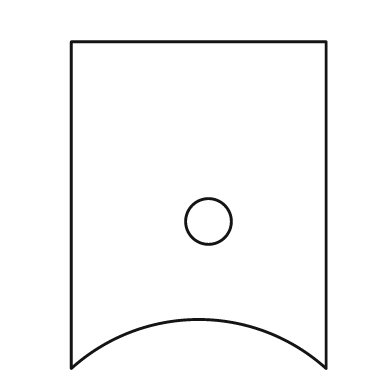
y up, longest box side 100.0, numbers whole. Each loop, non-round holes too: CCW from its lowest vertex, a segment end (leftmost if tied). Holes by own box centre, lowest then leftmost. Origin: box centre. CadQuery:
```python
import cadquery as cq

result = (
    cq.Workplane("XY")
    .moveTo(-39.0, -50.0)
    .threePointArc((0.0, -35.0), (39.0, -50.0))
    .lineTo(39.0, 50.0)
    .lineTo(-39.0, 50.0)
    .close()
    .moveTo(3.0, -5.0)
    .circle(7.0)
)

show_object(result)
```